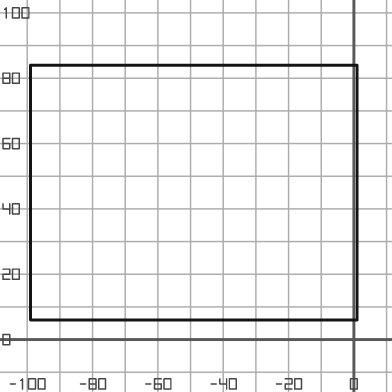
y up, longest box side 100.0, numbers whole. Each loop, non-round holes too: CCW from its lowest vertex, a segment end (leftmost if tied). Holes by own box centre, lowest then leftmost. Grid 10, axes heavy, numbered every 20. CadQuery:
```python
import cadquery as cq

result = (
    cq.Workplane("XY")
    .moveTo(-99.0, 6.0)
    .lineTo(1.0, 6.0)
    .lineTo(1.0, 84.0)
    .lineTo(-99.0, 84.0)
    .close()
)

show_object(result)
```